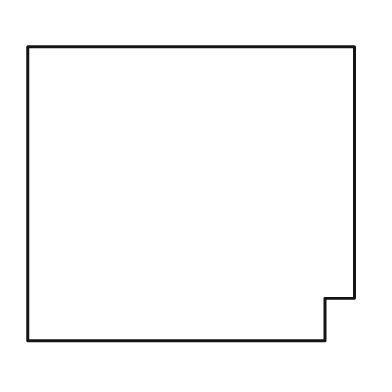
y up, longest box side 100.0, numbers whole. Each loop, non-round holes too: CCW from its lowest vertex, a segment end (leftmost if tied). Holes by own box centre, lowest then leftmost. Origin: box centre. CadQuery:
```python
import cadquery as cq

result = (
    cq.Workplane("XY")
    .moveTo(-50.0, -45.0)
    .lineTo(41.0, -45.0)
    .lineTo(41.0, -32.0)
    .lineTo(50.0, -32.0)
    .lineTo(50.0, 45.0)
    .lineTo(-50.0, 45.0)
    .close()
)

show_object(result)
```